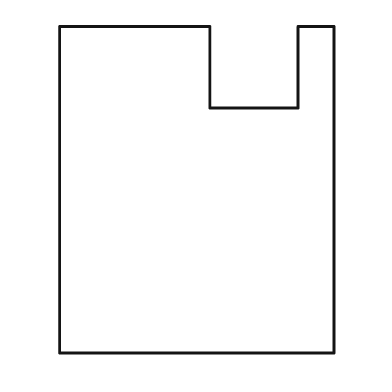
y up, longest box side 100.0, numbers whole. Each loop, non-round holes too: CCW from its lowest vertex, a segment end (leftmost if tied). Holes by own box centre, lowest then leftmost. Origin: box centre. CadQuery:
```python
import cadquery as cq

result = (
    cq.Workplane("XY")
    .moveTo(-42.0, -50.0)
    .lineTo(42.0, -50.0)
    .lineTo(42.0, 50.0)
    .lineTo(31.0, 50.0)
    .lineTo(31.0, 25.0)
    .lineTo(4.0, 25.0)
    .lineTo(4.0, 50.0)
    .lineTo(-42.0, 50.0)
    .close()
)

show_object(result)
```